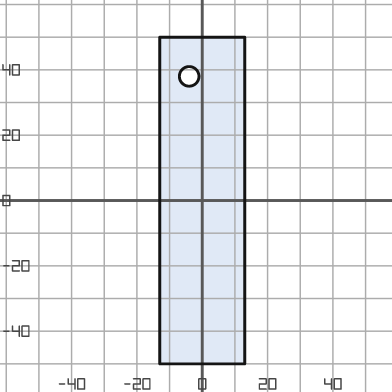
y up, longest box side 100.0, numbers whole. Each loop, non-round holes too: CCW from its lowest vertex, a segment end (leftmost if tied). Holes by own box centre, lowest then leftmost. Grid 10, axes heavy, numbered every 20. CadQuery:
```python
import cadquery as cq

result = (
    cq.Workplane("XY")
    .moveTo(-13.0, -50.0)
    .lineTo(13.0, -50.0)
    .lineTo(13.0, 50.0)
    .lineTo(-13.0, 50.0)
    .close()
    .moveTo(-4.0, 38.0)
    .circle(3.0)
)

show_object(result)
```